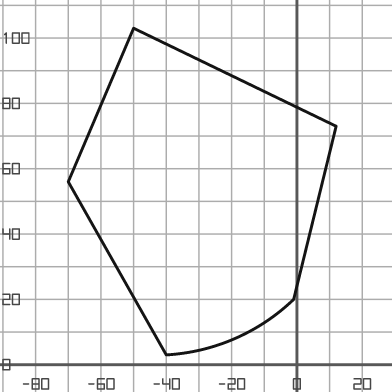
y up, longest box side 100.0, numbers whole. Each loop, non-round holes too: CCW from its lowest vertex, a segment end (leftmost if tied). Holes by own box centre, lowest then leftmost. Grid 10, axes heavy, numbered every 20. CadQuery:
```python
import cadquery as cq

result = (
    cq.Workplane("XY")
    .moveTo(-40.0, 3.0)
    .threePointArc((-19.0, 8.0), (-1.0, 20.0))
    .lineTo(12.0, 73.0)
    .lineTo(-50.0, 103.0)
    .lineTo(-70.0, 56.0)
    .close()
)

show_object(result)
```